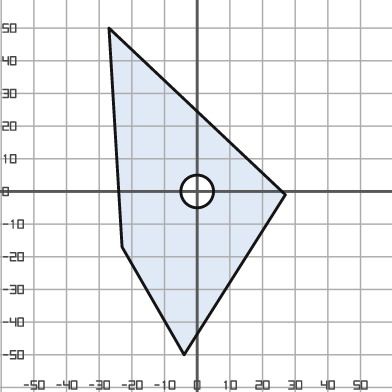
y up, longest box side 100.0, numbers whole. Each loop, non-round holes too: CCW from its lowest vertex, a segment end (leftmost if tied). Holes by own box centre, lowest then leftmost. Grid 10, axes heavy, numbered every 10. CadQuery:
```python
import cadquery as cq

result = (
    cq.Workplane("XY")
    .moveTo(-4.0, -50.0)
    .lineTo(27.0, -1.0)
    .lineTo(-27.0, 50.0)
    .lineTo(-23.0, -17.0)
    .close()
    .moveTo(0.0, 0.0)
    .circle(5.0)
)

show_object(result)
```